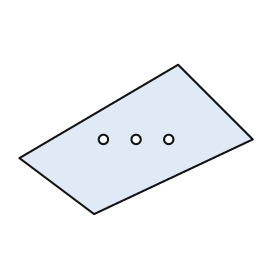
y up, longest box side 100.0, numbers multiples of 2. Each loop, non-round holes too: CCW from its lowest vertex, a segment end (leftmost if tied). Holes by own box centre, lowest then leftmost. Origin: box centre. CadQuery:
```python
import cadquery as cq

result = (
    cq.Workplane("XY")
    .moveTo(-18.0, -32.0)
    .lineTo(50.0, 0.0)
    .lineTo(18.0, 32.0)
    .lineTo(-50.0, -8.0)
    .close()
    .moveTo(-14.0, 0.0)
    .circle(2.0)
    .moveTo(0.0, 0.0)
    .circle(2.0)
    .moveTo(14.0, 0.0)
    .circle(2.0)
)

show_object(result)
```